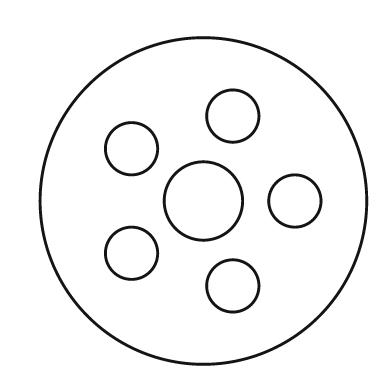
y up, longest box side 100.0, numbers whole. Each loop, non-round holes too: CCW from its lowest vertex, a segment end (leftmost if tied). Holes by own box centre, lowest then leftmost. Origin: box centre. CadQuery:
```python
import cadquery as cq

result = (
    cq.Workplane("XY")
    .moveTo(0.0, 0.0)
    .circle(50.0)
    .moveTo(9.0, -26.0)
    .circle(8.0)
    .moveTo(-22.0, -16.0)
    .circle(8.0)
    .moveTo(0.0, 0.0)
    .circle(12.0)
    .moveTo(28.0, 0.0)
    .circle(8.0)
    .moveTo(-22.0, 16.0)
    .circle(8.0)
    .moveTo(9.0, 26.0)
    .circle(8.0)
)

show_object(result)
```